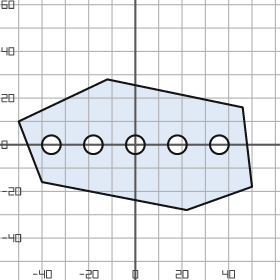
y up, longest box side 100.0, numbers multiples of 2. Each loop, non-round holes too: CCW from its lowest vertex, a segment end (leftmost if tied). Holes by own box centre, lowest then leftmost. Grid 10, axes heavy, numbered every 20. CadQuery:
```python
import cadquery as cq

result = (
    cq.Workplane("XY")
    .moveTo(22.0, -28.0)
    .lineTo(50.0, -18.0)
    .lineTo(46.0, 16.0)
    .lineTo(-12.0, 28.0)
    .lineTo(-50.0, 10.0)
    .lineTo(-40.0, -16.0)
    .close()
    .moveTo(-36.0, 0.0)
    .circle(4.0)
    .moveTo(-18.0, 0.0)
    .circle(4.0)
    .moveTo(0.0, 0.0)
    .circle(4.0)
    .moveTo(18.0, 0.0)
    .circle(4.0)
    .moveTo(36.0, 0.0)
    .circle(4.0)
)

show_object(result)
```